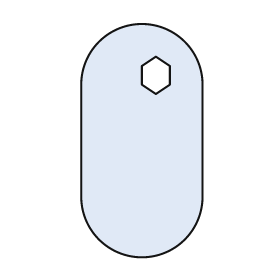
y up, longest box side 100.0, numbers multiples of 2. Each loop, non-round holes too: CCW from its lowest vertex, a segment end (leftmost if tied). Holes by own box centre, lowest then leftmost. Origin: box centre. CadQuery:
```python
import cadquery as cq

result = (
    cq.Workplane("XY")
    .moveTo(-26.0, -24.0)
    .threePointArc((0.0, -50.0), (26.0, -24.0))
    .lineTo(26.0, 24.0)
    .threePointArc((0.0, 50.0), (-26.0, 24.0))
    .close()
    .moveTo(6.0, 20.0)
    .lineTo(12.0, 24.0)
    .lineTo(12.0, 32.0)
    .lineTo(6.0, 36.0)
    .lineTo(0.0, 32.0)
    .lineTo(0.0, 24.0)
    .close()
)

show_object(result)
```